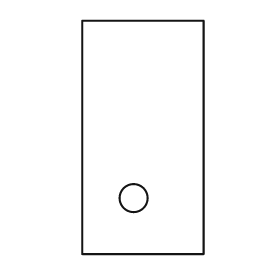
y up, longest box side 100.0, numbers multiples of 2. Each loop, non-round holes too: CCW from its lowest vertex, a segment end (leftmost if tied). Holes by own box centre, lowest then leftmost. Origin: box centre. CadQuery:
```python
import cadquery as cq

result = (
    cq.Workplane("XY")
    .moveTo(-26.0, -50.0)
    .lineTo(26.0, -50.0)
    .lineTo(26.0, 50.0)
    .lineTo(-26.0, 50.0)
    .close()
    .moveTo(-4.0, -26.0)
    .circle(6.0)
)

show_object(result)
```